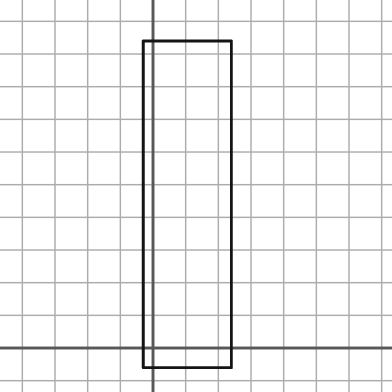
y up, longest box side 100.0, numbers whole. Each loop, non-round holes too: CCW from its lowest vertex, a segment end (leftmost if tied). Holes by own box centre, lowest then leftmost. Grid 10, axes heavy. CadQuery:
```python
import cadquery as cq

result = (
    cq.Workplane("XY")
    .moveTo(-3.0, -6.0)
    .lineTo(24.0, -6.0)
    .lineTo(24.0, 94.0)
    .lineTo(-3.0, 94.0)
    .close()
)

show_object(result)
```